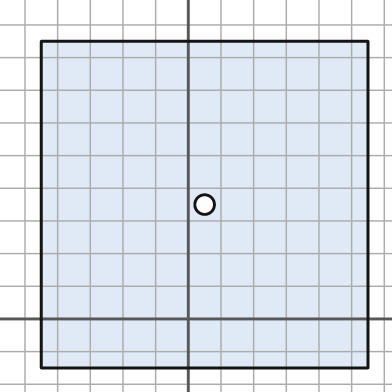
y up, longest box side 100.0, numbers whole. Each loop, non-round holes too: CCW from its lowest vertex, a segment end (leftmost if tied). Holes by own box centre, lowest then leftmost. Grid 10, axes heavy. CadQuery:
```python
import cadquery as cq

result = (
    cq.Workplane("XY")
    .moveTo(-45.0, -15.0)
    .lineTo(55.0, -15.0)
    .lineTo(55.0, 85.0)
    .lineTo(-45.0, 85.0)
    .close()
    .moveTo(5.0, 35.0)
    .circle(3.0)
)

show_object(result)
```